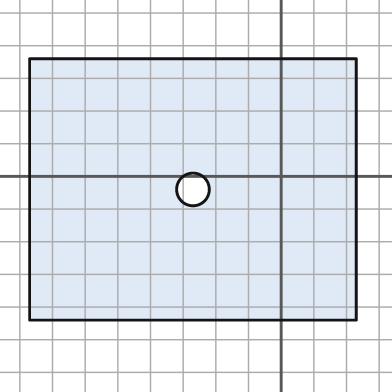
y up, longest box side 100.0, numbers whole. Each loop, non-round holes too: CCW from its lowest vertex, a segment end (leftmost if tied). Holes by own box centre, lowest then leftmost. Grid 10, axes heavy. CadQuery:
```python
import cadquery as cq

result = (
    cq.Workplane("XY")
    .moveTo(-77.0, -44.0)
    .lineTo(23.0, -44.0)
    .lineTo(23.0, 36.0)
    .lineTo(-77.0, 36.0)
    .close()
    .moveTo(-27.0, -4.0)
    .circle(5.0)
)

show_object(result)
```